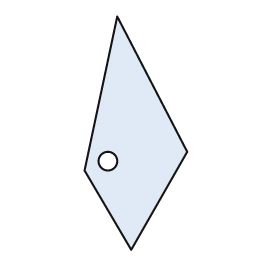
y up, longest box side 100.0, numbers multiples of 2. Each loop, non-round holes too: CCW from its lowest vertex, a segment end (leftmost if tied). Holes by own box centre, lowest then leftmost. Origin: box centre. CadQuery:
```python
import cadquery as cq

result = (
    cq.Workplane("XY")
    .moveTo(-2.0, -50.0)
    .lineTo(22.0, -8.0)
    .lineTo(-8.0, 50.0)
    .lineTo(-22.0, -16.0)
    .close()
    .moveTo(-12.0, -12.0)
    .circle(4.0)
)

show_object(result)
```